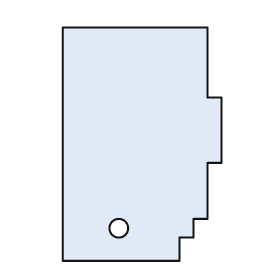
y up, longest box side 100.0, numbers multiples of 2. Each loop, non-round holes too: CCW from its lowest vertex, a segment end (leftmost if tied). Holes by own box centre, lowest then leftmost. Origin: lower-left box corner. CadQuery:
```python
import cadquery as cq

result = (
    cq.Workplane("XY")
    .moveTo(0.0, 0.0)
    .lineTo(50.0, 0.0)
    .lineTo(50.0, 10.0)
    .lineTo(56.0, 10.0)
    .lineTo(56.0, 18.0)
    .lineTo(62.0, 18.0)
    .lineTo(62.0, 42.0)
    .lineTo(68.0, 42.0)
    .lineTo(68.0, 70.0)
    .lineTo(62.0, 70.0)
    .lineTo(62.0, 100.0)
    .lineTo(0.0, 100.0)
    .close()
    .moveTo(24.0, 14.0)
    .circle(4.0)
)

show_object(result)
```